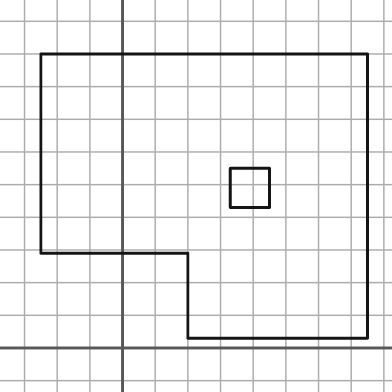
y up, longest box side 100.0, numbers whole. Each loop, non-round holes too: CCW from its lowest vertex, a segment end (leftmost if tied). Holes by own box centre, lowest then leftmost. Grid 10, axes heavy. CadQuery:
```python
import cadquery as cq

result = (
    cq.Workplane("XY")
    .moveTo(20.0, 3.0)
    .lineTo(75.0, 3.0)
    .lineTo(75.0, 90.0)
    .lineTo(-25.0, 90.0)
    .lineTo(-25.0, 29.0)
    .lineTo(20.0, 29.0)
    .close()
    .moveTo(33.0, 43.0)
    .lineTo(45.0, 43.0)
    .lineTo(45.0, 55.0)
    .lineTo(33.0, 55.0)
    .close()
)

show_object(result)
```